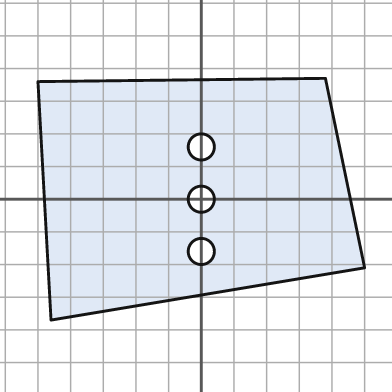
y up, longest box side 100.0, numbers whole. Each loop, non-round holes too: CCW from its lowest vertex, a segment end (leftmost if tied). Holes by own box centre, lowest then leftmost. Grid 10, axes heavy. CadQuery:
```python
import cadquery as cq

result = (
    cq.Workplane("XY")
    .moveTo(-46.0, -37.0)
    .lineTo(50.0, -21.0)
    .lineTo(38.0, 37.0)
    .lineTo(-50.0, 36.0)
    .close()
    .moveTo(0.0, -16.0)
    .circle(4.0)
    .moveTo(0.0, 0.0)
    .circle(4.0)
    .moveTo(0.0, 16.0)
    .circle(4.0)
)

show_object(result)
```